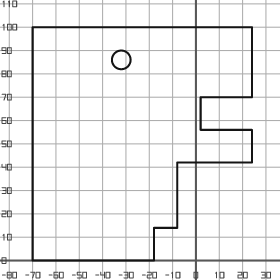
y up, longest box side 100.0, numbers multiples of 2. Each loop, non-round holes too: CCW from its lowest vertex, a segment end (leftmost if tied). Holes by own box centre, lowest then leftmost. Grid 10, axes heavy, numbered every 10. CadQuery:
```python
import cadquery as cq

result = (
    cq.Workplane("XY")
    .moveTo(-70.0, 0.0)
    .lineTo(-18.0, 0.0)
    .lineTo(-18.0, 14.0)
    .lineTo(-8.0, 14.0)
    .lineTo(-8.0, 42.0)
    .lineTo(24.0, 42.0)
    .lineTo(24.0, 56.0)
    .lineTo(2.0, 56.0)
    .lineTo(2.0, 70.0)
    .lineTo(24.0, 70.0)
    .lineTo(24.0, 100.0)
    .lineTo(-70.0, 100.0)
    .close()
    .moveTo(-32.0, 86.0)
    .circle(4.0)
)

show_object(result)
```